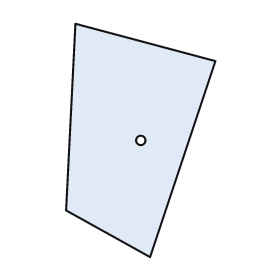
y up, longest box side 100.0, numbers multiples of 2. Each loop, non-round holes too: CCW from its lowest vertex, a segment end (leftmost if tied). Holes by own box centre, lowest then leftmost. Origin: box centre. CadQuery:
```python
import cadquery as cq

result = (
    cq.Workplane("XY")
    .moveTo(4.0, -50.0)
    .lineTo(32.0, 34.0)
    .lineTo(-28.0, 50.0)
    .lineTo(-32.0, -30.0)
    .close()
    .moveTo(0.0, 0.0)
    .circle(2.0)
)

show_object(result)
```